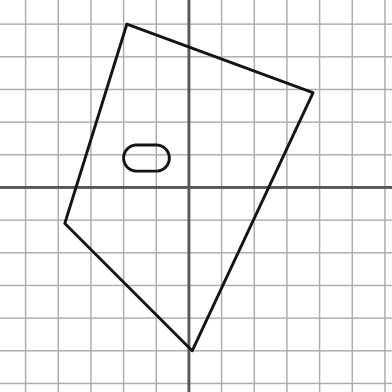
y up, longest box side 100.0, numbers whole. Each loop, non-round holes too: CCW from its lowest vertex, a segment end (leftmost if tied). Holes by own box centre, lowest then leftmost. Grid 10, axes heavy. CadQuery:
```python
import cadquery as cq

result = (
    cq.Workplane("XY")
    .moveTo(1.0, -50.0)
    .lineTo(38.0, 29.0)
    .lineTo(-19.0, 50.0)
    .lineTo(-38.0, -11.0)
    .close()
    .moveTo(-16.0, 5.0)
    .lineTo(-10.0, 5.0)
    .threePointArc((-6.0, 9.0), (-10.0, 13.0))
    .lineTo(-16.0, 13.0)
    .threePointArc((-20.0, 9.0), (-16.0, 5.0))
    .close()
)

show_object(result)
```